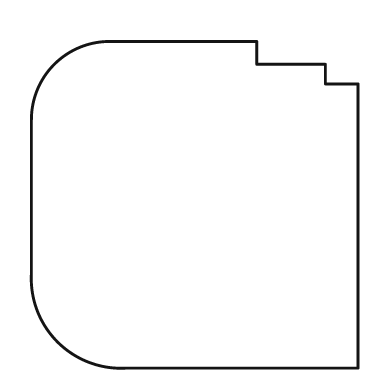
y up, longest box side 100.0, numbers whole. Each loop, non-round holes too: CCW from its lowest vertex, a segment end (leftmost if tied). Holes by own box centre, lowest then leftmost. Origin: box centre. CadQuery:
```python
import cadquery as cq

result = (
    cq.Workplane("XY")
    .moveTo(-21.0, -50.0)
    .lineTo(50.0, -50.0)
    .lineTo(50.0, 37.0)
    .lineTo(40.0, 37.0)
    .lineTo(40.0, 43.0)
    .lineTo(19.0, 43.0)
    .lineTo(19.0, 50.0)
    .lineTo(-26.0, 50.0)
    .threePointArc((-43.0, 43.0), (-50.0, 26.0))
    .lineTo(-50.0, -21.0)
    .threePointArc((-42.0, -42.0), (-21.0, -50.0))
    .close()
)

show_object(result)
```